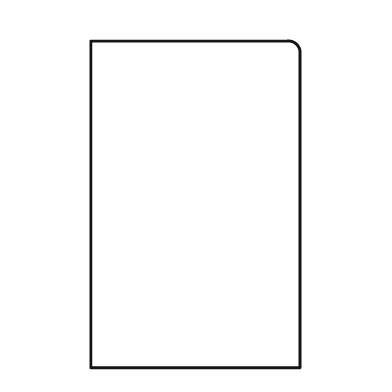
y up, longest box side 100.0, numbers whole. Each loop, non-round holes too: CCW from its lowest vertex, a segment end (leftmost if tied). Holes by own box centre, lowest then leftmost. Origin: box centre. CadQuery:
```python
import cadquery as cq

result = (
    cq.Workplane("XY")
    .moveTo(-32.0, -50.0)
    .lineTo(32.0, -50.0)
    .lineTo(32.0, 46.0)
    .threePointArc((31.0, 49.0), (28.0, 50.0))
    .lineTo(-32.0, 50.0)
    .close()
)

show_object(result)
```